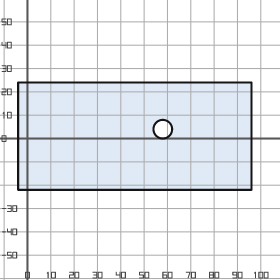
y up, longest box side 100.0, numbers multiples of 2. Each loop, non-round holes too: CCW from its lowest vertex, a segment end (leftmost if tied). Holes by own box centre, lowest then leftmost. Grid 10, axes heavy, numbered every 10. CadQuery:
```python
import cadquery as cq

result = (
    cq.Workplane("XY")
    .moveTo(-4.0, -22.0)
    .lineTo(96.0, -22.0)
    .lineTo(96.0, 24.0)
    .lineTo(-4.0, 24.0)
    .close()
    .moveTo(58.0, 4.0)
    .circle(4.0)
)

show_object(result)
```